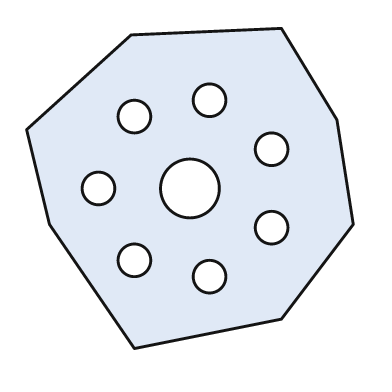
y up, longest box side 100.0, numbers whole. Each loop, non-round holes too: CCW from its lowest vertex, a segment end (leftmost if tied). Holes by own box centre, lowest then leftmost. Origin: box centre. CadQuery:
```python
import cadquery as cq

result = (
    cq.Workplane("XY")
    .moveTo(-17.0, -49.0)
    .lineTo(28.0, -40.0)
    .lineTo(50.0, -11.0)
    .lineTo(45.0, 21.0)
    .lineTo(28.0, 49.0)
    .lineTo(-18.0, 47.0)
    .lineTo(-50.0, 18.0)
    .lineTo(-43.0, -11.0)
    .close()
    .moveTo(6.0, -27.0)
    .circle(5.0)
    .moveTo(-17.0, -22.0)
    .circle(5.0)
    .moveTo(25.0, -12.0)
    .circle(5.0)
    .moveTo(-28.0, 0.0)
    .circle(5.0)
    .moveTo(0.0, 0.0)
    .circle(9.0)
    .moveTo(25.0, 12.0)
    .circle(5.0)
    .moveTo(-17.0, 22.0)
    .circle(5.0)
    .moveTo(6.0, 27.0)
    .circle(5.0)
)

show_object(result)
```